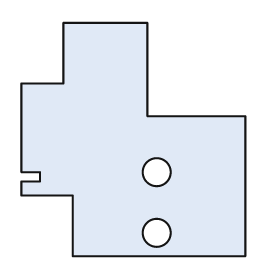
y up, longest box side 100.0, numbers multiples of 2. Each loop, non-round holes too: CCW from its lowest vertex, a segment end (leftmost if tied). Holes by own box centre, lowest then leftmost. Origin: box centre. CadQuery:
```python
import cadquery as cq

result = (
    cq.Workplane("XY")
    .moveTo(-26.0, -50.0)
    .lineTo(48.0, -50.0)
    .lineTo(48.0, 10.0)
    .lineTo(6.0, 10.0)
    .lineTo(6.0, 50.0)
    .lineTo(-30.0, 50.0)
    .lineTo(-30.0, 24.0)
    .lineTo(-48.0, 24.0)
    .lineTo(-48.0, -14.0)
    .lineTo(-40.0, -14.0)
    .lineTo(-40.0, -18.0)
    .lineTo(-48.0, -18.0)
    .lineTo(-48.0, -24.0)
    .lineTo(-26.0, -24.0)
    .close()
    .moveTo(10.0, -40.0)
    .circle(6.0)
    .moveTo(10.0, -14.0)
    .circle(6.0)
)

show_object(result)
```